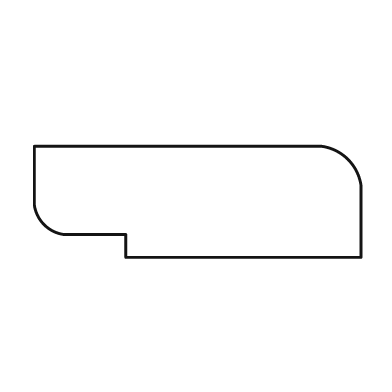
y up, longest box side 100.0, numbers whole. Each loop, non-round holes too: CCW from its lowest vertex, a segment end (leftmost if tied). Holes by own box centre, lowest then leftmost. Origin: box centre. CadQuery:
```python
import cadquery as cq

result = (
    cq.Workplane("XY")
    .moveTo(-22.0, -17.0)
    .lineTo(50.0, -17.0)
    .lineTo(50.0, 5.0)
    .threePointArc((46.0, 13.0), (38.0, 17.0))
    .lineTo(-50.0, 17.0)
    .lineTo(-50.0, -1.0)
    .threePointArc((-47.0, -7.0), (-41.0, -10.0))
    .lineTo(-22.0, -10.0)
    .close()
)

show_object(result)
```